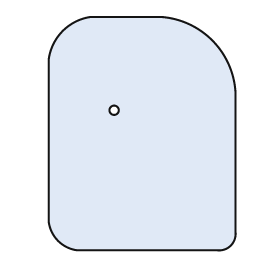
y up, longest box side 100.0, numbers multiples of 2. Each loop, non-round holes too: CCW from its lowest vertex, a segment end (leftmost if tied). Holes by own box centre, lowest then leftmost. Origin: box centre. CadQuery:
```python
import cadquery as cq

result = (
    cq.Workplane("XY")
    .moveTo(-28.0, -50.0)
    .lineTo(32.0, -50.0)
    .threePointArc((38.0, -48.0), (40.0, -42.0))
    .lineTo(40.0, 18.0)
    .threePointArc((30.0, 40.0), (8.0, 50.0))
    .lineTo(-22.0, 50.0)
    .threePointArc((-34.0, 44.0), (-40.0, 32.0))
    .lineTo(-40.0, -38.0)
    .threePointArc((-36.0, -46.0), (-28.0, -50.0))
    .close()
    .moveTo(-12.0, 10.0)
    .circle(2.0)
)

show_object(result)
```